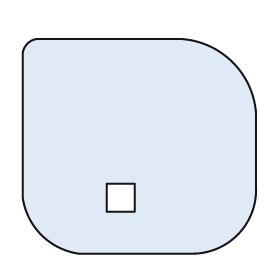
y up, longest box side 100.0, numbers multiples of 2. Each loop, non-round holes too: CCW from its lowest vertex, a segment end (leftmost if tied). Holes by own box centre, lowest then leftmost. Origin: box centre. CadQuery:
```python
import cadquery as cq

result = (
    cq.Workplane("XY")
    .moveTo(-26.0, -46.0)
    .lineTo(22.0, -46.0)
    .threePointArc((42.0, -38.0), (50.0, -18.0))
    .lineTo(50.0, 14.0)
    .threePointArc((40.0, 36.0), (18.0, 46.0))
    .lineTo(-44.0, 46.0)
    .threePointArc((-48.0, 44.0), (-50.0, 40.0))
    .lineTo(-50.0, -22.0)
    .threePointArc((-42.0, -38.0), (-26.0, -46.0))
    .close()
    .moveTo(-14.0, -28.0)
    .lineTo(-2.0, -28.0)
    .lineTo(-2.0, -16.0)
    .lineTo(-14.0, -16.0)
    .close()
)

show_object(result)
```